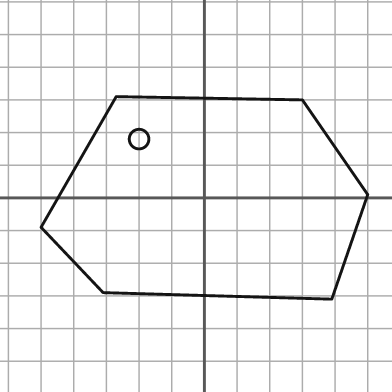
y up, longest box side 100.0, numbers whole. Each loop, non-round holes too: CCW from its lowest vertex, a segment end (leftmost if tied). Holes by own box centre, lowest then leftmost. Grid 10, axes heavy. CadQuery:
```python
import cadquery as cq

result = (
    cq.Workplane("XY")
    .moveTo(39.0, -31.0)
    .lineTo(50.0, 1.0)
    .lineTo(30.0, 30.0)
    .lineTo(-27.0, 31.0)
    .lineTo(-50.0, -9.0)
    .lineTo(-31.0, -29.0)
    .close()
    .moveTo(-20.0, 18.0)
    .circle(3.0)
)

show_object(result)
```